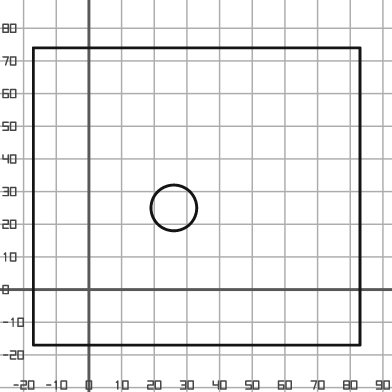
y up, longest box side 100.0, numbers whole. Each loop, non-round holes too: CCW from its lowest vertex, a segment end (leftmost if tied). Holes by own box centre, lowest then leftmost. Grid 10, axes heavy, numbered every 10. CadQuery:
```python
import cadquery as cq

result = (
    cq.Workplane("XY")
    .moveTo(-17.0, -17.0)
    .lineTo(83.0, -17.0)
    .lineTo(83.0, 74.0)
    .lineTo(-17.0, 74.0)
    .close()
    .moveTo(26.0, 25.0)
    .circle(7.0)
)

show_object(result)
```